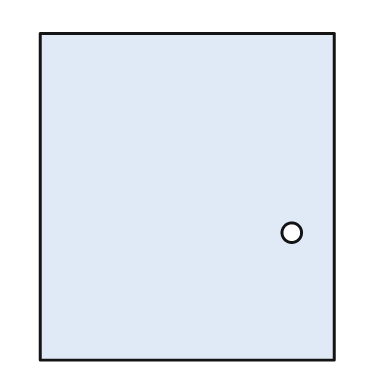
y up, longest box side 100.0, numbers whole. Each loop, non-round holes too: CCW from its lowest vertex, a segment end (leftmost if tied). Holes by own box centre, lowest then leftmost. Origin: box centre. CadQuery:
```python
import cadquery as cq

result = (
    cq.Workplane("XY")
    .moveTo(-45.0, -50.0)
    .lineTo(45.0, -50.0)
    .lineTo(45.0, 50.0)
    .lineTo(-45.0, 50.0)
    .close()
    .moveTo(32.0, -11.0)
    .circle(3.0)
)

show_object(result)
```